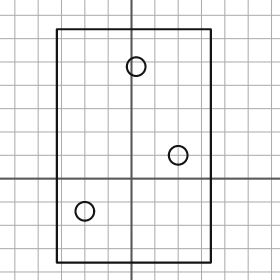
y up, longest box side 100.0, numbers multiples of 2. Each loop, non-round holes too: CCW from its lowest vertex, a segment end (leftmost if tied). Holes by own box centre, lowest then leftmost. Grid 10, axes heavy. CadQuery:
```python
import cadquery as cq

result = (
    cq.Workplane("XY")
    .moveTo(-32.0, -36.0)
    .lineTo(34.0, -36.0)
    .lineTo(34.0, 64.0)
    .lineTo(-32.0, 64.0)
    .close()
    .moveTo(-20.0, -14.0)
    .circle(4.0)
    .moveTo(20.0, 10.0)
    .circle(4.0)
    .moveTo(2.0, 48.0)
    .circle(4.0)
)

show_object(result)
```